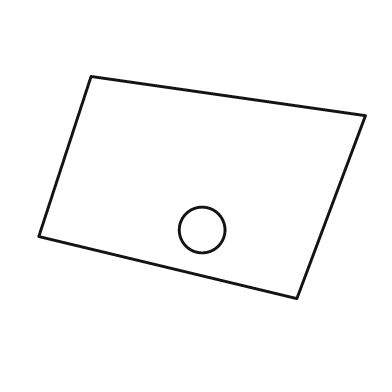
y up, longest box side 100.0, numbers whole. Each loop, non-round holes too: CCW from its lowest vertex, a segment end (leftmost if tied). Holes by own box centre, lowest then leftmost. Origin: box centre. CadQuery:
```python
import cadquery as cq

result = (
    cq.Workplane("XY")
    .moveTo(29.0, -34.0)
    .lineTo(50.0, 22.0)
    .lineTo(-34.0, 34.0)
    .lineTo(-50.0, -15.0)
    .close()
    .moveTo(0.0, -13.0)
    .circle(7.0)
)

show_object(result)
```